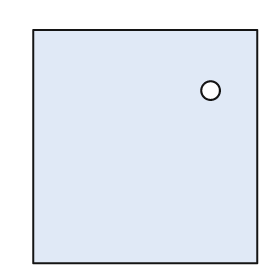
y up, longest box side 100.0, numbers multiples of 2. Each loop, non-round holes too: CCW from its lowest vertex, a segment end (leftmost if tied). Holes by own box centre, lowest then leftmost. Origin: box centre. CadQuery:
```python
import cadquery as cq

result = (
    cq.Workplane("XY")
    .moveTo(-48.0, -50.0)
    .lineTo(48.0, -50.0)
    .lineTo(48.0, 50.0)
    .lineTo(-48.0, 50.0)
    .close()
    .moveTo(28.0, 24.0)
    .circle(4.0)
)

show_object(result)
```